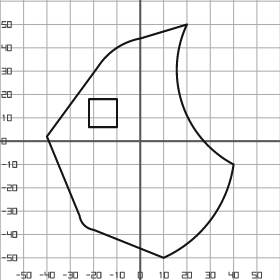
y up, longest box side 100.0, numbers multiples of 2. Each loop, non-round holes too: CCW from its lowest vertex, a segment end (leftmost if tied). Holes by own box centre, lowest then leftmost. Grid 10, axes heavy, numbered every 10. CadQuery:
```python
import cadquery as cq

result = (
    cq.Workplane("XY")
    .moveTo(10.0, -50.0)
    .threePointArc((30.0, -34.0), (40.0, -10.0))
    .threePointArc((18.0, 16.0), (20.0, 50.0))
    .lineTo(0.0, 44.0)
    .threePointArc((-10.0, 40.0), (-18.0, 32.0))
    .lineTo(-40.0, 2.0)
    .lineTo(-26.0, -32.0)
    .threePointArc((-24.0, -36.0), (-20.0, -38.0))
    .close()
    .moveTo(-22.0, 6.0)
    .lineTo(-10.0, 6.0)
    .lineTo(-10.0, 18.0)
    .lineTo(-22.0, 18.0)
    .close()
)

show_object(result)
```